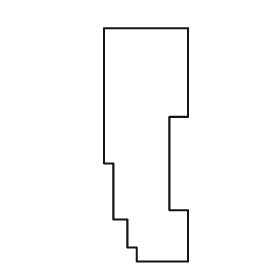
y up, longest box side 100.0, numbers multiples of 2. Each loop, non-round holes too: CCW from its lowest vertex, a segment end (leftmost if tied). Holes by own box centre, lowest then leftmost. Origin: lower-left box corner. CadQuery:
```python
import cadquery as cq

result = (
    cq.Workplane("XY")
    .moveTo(14.0, 0.0)
    .lineTo(36.0, 0.0)
    .lineTo(36.0, 22.0)
    .lineTo(28.0, 22.0)
    .lineTo(28.0, 62.0)
    .lineTo(36.0, 62.0)
    .lineTo(36.0, 100.0)
    .lineTo(0.0, 100.0)
    .lineTo(0.0, 42.0)
    .lineTo(4.0, 42.0)
    .lineTo(4.0, 18.0)
    .lineTo(10.0, 18.0)
    .lineTo(10.0, 6.0)
    .lineTo(14.0, 6.0)
    .close()
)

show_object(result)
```